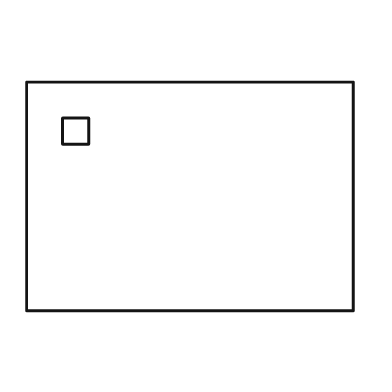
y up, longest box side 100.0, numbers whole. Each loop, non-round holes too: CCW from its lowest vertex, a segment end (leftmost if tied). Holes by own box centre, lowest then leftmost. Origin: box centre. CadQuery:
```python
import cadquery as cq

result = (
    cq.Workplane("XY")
    .moveTo(-50.0, -35.0)
    .lineTo(50.0, -35.0)
    .lineTo(50.0, 35.0)
    .lineTo(-50.0, 35.0)
    .close()
    .moveTo(-39.0, 16.0)
    .lineTo(-31.0, 16.0)
    .lineTo(-31.0, 24.0)
    .lineTo(-39.0, 24.0)
    .close()
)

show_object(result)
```